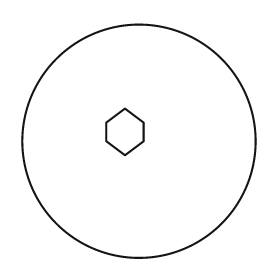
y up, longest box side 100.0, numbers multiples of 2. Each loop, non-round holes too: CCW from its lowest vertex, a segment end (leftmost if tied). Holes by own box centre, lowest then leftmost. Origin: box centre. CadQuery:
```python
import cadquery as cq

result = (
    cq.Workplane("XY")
    .moveTo(0.0, 0.0)
    .circle(50.0)
    .moveTo(-6.0, -6.0)
    .lineTo(2.0, 0.0)
    .lineTo(2.0, 8.0)
    .lineTo(-6.0, 14.0)
    .lineTo(-14.0, 8.0)
    .lineTo(-14.0, 0.0)
    .close()
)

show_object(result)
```